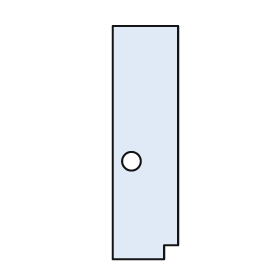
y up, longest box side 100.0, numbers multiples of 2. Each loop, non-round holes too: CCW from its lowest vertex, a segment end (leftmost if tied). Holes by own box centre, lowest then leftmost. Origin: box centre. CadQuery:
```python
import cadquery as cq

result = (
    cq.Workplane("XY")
    .moveTo(-14.0, -50.0)
    .lineTo(8.0, -50.0)
    .lineTo(8.0, -44.0)
    .lineTo(14.0, -44.0)
    .lineTo(14.0, 50.0)
    .lineTo(-14.0, 50.0)
    .close()
    .moveTo(-6.0, -8.0)
    .circle(4.0)
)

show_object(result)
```